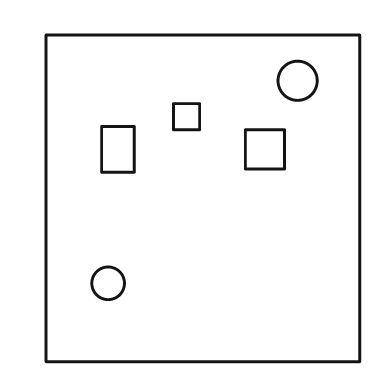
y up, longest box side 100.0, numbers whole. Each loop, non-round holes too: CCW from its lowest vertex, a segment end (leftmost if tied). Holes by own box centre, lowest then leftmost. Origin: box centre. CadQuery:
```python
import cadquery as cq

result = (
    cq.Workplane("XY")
    .moveTo(-48.0, -50.0)
    .lineTo(48.0, -50.0)
    .lineTo(48.0, 50.0)
    .lineTo(-48.0, 50.0)
    .close()
    .moveTo(-29.0, -26.0)
    .circle(5.0)
    .moveTo(-31.0, 8.0)
    .lineTo(-21.0, 8.0)
    .lineTo(-21.0, 22.0)
    .lineTo(-31.0, 22.0)
    .close()
    .moveTo(13.0, 9.0)
    .lineTo(25.0, 9.0)
    .lineTo(25.0, 21.0)
    .lineTo(13.0, 21.0)
    .close()
    .moveTo(-9.0, 21.0)
    .lineTo(-1.0, 21.0)
    .lineTo(-1.0, 29.0)
    .lineTo(-9.0, 29.0)
    .close()
    .moveTo(29.0, 36.0)
    .circle(6.0)
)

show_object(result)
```